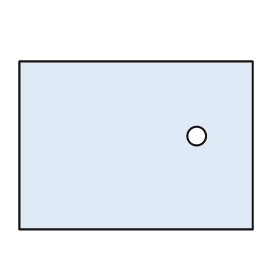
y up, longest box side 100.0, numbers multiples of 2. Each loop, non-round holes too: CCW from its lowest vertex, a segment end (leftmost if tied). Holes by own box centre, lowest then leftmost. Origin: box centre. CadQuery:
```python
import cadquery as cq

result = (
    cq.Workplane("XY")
    .moveTo(-50.0, -36.0)
    .lineTo(50.0, -36.0)
    .lineTo(50.0, 36.0)
    .lineTo(-50.0, 36.0)
    .close()
    .moveTo(26.0, 4.0)
    .circle(4.0)
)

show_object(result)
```